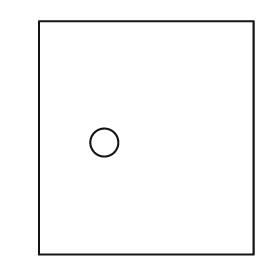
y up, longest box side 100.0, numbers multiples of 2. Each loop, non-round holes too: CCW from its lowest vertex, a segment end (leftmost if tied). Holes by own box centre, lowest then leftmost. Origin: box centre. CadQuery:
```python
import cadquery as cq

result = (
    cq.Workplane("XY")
    .moveTo(-46.0, -50.0)
    .lineTo(46.0, -50.0)
    .lineTo(46.0, 50.0)
    .lineTo(-46.0, 50.0)
    .close()
    .moveTo(-18.0, -2.0)
    .circle(6.0)
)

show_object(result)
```